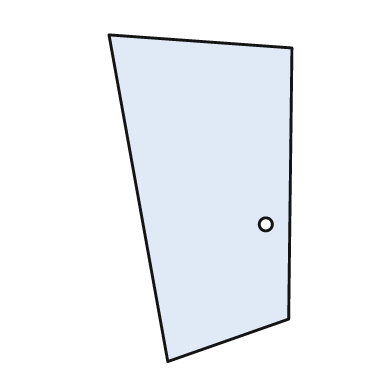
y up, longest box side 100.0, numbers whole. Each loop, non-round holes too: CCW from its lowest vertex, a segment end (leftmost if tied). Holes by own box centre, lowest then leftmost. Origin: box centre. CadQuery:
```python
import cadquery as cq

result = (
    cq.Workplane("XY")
    .moveTo(-10.0, -50.0)
    .lineTo(27.0, -37.0)
    .lineTo(28.0, 46.0)
    .lineTo(-28.0, 50.0)
    .close()
    .moveTo(20.0, -8.0)
    .circle(2.0)
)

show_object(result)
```